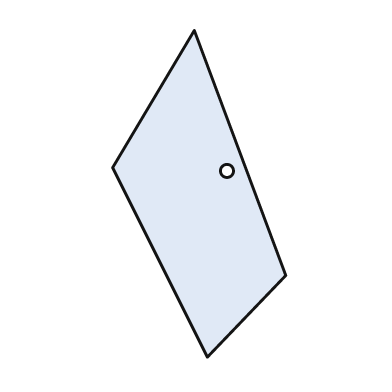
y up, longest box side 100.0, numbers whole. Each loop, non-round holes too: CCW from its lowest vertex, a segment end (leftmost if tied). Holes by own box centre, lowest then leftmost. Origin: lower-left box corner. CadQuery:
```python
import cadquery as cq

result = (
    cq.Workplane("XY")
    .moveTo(29.0, 0.0)
    .lineTo(53.0, 25.0)
    .lineTo(25.0, 100.0)
    .lineTo(0.0, 58.0)
    .close()
    .moveTo(35.0, 57.0)
    .circle(2.0)
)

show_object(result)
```